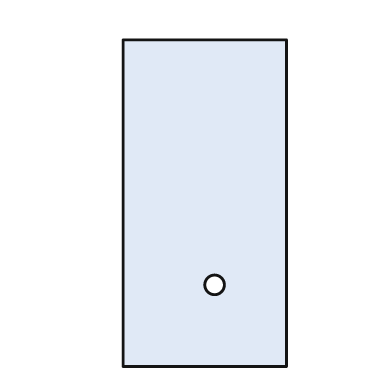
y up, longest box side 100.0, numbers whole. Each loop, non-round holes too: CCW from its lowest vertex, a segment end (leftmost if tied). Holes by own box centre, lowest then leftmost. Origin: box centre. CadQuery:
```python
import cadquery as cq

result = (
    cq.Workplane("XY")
    .moveTo(-25.0, -50.0)
    .lineTo(25.0, -50.0)
    .lineTo(25.0, 50.0)
    .lineTo(-25.0, 50.0)
    .close()
    .moveTo(3.0, -25.0)
    .circle(3.0)
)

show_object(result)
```